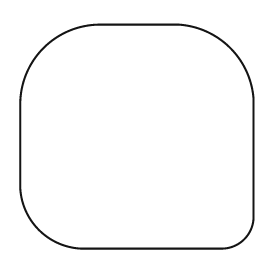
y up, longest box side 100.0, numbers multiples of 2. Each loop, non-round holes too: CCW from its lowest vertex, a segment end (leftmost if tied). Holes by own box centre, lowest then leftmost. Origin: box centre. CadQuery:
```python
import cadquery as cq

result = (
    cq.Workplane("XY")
    .moveTo(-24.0, -48.0)
    .lineTo(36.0, -48.0)
    .threePointArc((46.0, -44.0), (50.0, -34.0))
    .lineTo(50.0, 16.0)
    .threePointArc((40.0, 38.0), (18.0, 48.0))
    .lineTo(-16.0, 48.0)
    .threePointArc((-40.0, 38.0), (-50.0, 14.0))
    .lineTo(-50.0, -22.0)
    .threePointArc((-42.0, -40.0), (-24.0, -48.0))
    .close()
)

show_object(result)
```